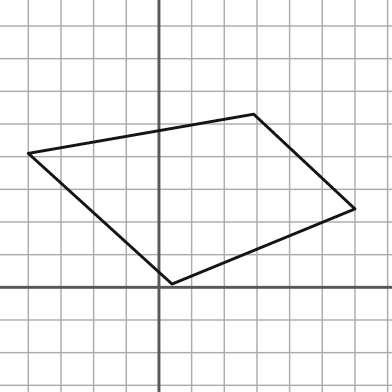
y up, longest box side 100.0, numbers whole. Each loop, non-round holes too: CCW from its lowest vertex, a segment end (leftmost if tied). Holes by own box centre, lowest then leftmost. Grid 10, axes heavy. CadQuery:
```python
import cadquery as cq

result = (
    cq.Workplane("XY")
    .moveTo(4.0, 1.0)
    .lineTo(60.0, 24.0)
    .lineTo(29.0, 53.0)
    .lineTo(-40.0, 41.0)
    .close()
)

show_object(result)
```